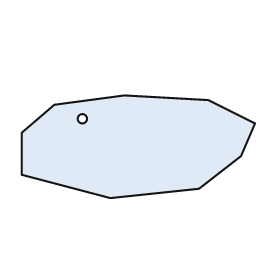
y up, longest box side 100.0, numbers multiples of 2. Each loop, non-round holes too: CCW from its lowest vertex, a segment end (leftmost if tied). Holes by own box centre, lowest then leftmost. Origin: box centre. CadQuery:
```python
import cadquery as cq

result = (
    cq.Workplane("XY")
    .moveTo(-12.0, -22.0)
    .lineTo(26.0, -18.0)
    .lineTo(44.0, -4.0)
    .lineTo(50.0, 10.0)
    .lineTo(30.0, 20.0)
    .lineTo(-6.0, 22.0)
    .lineTo(-36.0, 18.0)
    .lineTo(-50.0, 6.0)
    .lineTo(-50.0, -12.0)
    .close()
    .moveTo(-24.0, 12.0)
    .circle(2.0)
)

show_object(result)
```